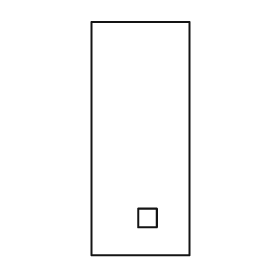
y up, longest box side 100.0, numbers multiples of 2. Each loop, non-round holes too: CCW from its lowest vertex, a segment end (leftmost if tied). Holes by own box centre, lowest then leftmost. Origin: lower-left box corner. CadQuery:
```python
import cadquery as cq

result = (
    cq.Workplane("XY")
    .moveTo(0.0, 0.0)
    .lineTo(42.0, 0.0)
    .lineTo(42.0, 100.0)
    .lineTo(0.0, 100.0)
    .close()
    .moveTo(20.0, 12.0)
    .lineTo(28.0, 12.0)
    .lineTo(28.0, 20.0)
    .lineTo(20.0, 20.0)
    .close()
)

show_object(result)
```